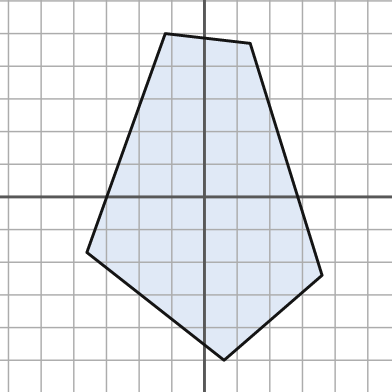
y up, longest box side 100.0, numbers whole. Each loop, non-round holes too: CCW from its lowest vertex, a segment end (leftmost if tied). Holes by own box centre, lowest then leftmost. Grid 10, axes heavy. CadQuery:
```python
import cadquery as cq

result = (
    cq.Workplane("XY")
    .moveTo(6.0, -50.0)
    .lineTo(36.0, -24.0)
    .lineTo(14.0, 47.0)
    .lineTo(-12.0, 50.0)
    .lineTo(-36.0, -17.0)
    .close()
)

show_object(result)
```